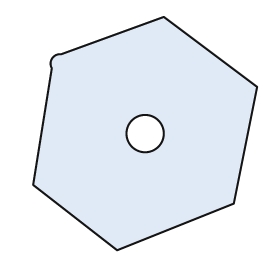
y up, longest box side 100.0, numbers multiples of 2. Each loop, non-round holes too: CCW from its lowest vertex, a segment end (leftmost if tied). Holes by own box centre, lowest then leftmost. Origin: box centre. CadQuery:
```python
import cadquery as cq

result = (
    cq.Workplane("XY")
    .moveTo(-12.0, -50.0)
    .lineTo(38.0, -30.0)
    .lineTo(48.0, 20.0)
    .lineTo(8.0, 50.0)
    .lineTo(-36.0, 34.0)
    .threePointArc((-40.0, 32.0), (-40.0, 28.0))
    .lineTo(-48.0, -22.0)
    .close()
    .moveTo(0.0, 0.0)
    .circle(8.0)
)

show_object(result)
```